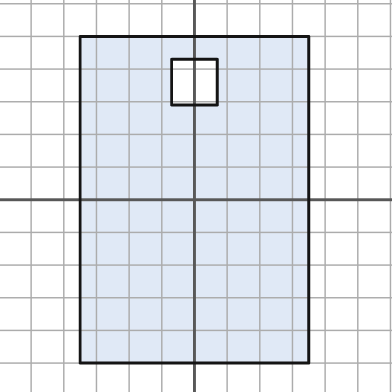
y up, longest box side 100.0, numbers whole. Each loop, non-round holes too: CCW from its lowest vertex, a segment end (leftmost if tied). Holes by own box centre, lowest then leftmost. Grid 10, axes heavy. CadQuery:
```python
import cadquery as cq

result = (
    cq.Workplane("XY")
    .moveTo(-35.0, -50.0)
    .lineTo(35.0, -50.0)
    .lineTo(35.0, 50.0)
    .lineTo(-35.0, 50.0)
    .close()
    .moveTo(-7.0, 29.0)
    .lineTo(7.0, 29.0)
    .lineTo(7.0, 43.0)
    .lineTo(-7.0, 43.0)
    .close()
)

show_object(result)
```